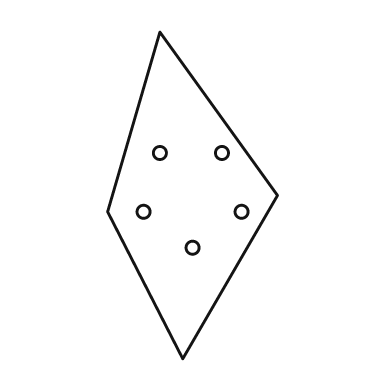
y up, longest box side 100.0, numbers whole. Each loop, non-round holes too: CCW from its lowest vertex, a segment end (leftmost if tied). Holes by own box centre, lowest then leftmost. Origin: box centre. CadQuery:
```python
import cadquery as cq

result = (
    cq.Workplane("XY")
    .moveTo(-3.0, -50.0)
    .lineTo(26.0, 0.0)
    .lineTo(-10.0, 50.0)
    .lineTo(-26.0, -5.0)
    .close()
    .moveTo(0.0, -16.0)
    .circle(2.0)
    .moveTo(-15.0, -5.0)
    .circle(2.0)
    .moveTo(15.0, -5.0)
    .circle(2.0)
    .moveTo(-10.0, 13.0)
    .circle(2.0)
    .moveTo(9.0, 13.0)
    .circle(2.0)
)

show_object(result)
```